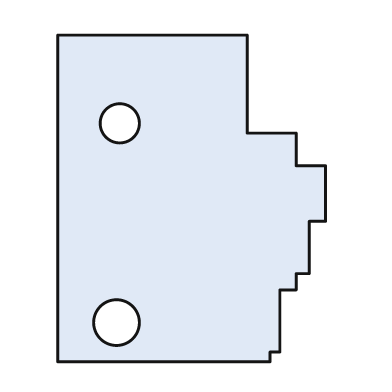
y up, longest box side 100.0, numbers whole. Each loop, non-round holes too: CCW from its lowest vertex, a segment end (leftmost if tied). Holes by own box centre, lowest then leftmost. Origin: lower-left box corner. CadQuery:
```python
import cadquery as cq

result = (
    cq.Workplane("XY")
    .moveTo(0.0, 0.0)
    .lineTo(65.0, 0.0)
    .lineTo(65.0, 3.0)
    .lineTo(68.0, 3.0)
    .lineTo(68.0, 22.0)
    .lineTo(73.0, 22.0)
    .lineTo(73.0, 27.0)
    .lineTo(77.0, 27.0)
    .lineTo(77.0, 43.0)
    .lineTo(82.0, 43.0)
    .lineTo(82.0, 60.0)
    .lineTo(73.0, 60.0)
    .lineTo(73.0, 70.0)
    .lineTo(58.0, 70.0)
    .lineTo(58.0, 100.0)
    .lineTo(0.0, 100.0)
    .close()
    .moveTo(18.0, 12.0)
    .circle(7.0)
    .moveTo(19.0, 73.0)
    .circle(6.0)
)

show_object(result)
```